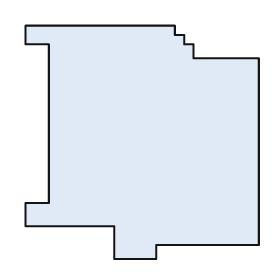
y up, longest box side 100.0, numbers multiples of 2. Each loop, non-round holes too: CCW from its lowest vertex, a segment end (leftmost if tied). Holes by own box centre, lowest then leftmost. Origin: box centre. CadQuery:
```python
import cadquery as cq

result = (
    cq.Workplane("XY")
    .moveTo(-12.0, -50.0)
    .lineTo(6.0, -50.0)
    .lineTo(6.0, -44.0)
    .lineTo(50.0, -44.0)
    .lineTo(50.0, 36.0)
    .lineTo(22.0, 36.0)
    .lineTo(22.0, 42.0)
    .lineTo(18.0, 42.0)
    .lineTo(18.0, 46.0)
    .lineTo(14.0, 46.0)
    .lineTo(14.0, 50.0)
    .lineTo(-50.0, 50.0)
    .lineTo(-50.0, 42.0)
    .lineTo(-40.0, 42.0)
    .lineTo(-40.0, -26.0)
    .lineTo(-50.0, -26.0)
    .lineTo(-50.0, -36.0)
    .lineTo(-12.0, -36.0)
    .close()
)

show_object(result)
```